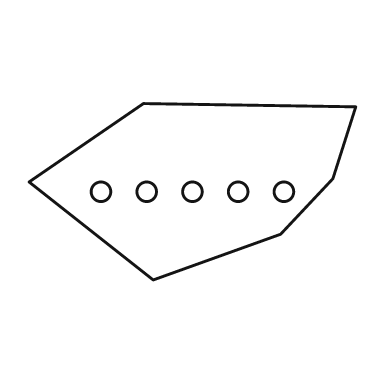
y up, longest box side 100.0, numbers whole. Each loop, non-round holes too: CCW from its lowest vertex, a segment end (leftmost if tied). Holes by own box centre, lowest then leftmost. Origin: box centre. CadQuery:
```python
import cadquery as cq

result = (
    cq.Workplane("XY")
    .moveTo(-12.0, -27.0)
    .lineTo(27.0, -13.0)
    .lineTo(43.0, 4.0)
    .lineTo(50.0, 26.0)
    .lineTo(-15.0, 27.0)
    .lineTo(-50.0, 3.0)
    .close()
    .moveTo(-28.0, 0.0)
    .circle(3.0)
    .moveTo(-14.0, 0.0)
    .circle(3.0)
    .moveTo(0.0, 0.0)
    .circle(3.0)
    .moveTo(14.0, 0.0)
    .circle(3.0)
    .moveTo(28.0, 0.0)
    .circle(3.0)
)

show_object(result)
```